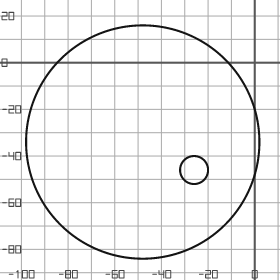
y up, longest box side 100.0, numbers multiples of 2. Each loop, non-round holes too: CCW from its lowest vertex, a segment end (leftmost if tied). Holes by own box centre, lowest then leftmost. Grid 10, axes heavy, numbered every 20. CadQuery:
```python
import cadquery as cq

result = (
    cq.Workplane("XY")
    .moveTo(-48.0, -34.0)
    .circle(50.0)
    .moveTo(-26.0, -46.0)
    .circle(6.0)
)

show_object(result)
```